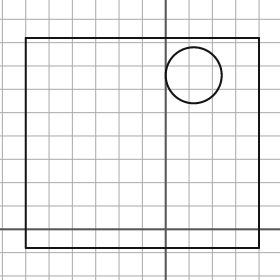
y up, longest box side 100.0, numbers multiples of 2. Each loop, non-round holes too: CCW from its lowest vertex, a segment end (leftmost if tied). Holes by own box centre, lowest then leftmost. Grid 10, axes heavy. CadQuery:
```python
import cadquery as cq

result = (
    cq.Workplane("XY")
    .moveTo(-60.0, -8.0)
    .lineTo(40.0, -8.0)
    .lineTo(40.0, 82.0)
    .lineTo(-60.0, 82.0)
    .close()
    .moveTo(12.0, 66.0)
    .circle(12.0)
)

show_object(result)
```